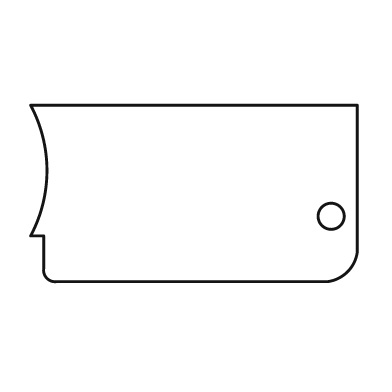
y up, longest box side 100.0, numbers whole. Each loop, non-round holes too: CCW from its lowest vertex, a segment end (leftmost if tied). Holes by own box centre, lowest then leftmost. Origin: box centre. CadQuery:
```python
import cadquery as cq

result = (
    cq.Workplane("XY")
    .moveTo(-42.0, -27.0)
    .lineTo(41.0, -27.0)
    .threePointArc((47.0, -24.0), (50.0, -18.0))
    .lineTo(50.0, 27.0)
    .lineTo(-50.0, 27.0)
    .threePointArc((-45.0, 7.0), (-50.0, -13.0))
    .lineTo(-46.0, -13.0)
    .lineTo(-46.0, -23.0)
    .threePointArc((-45.0, -26.0), (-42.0, -27.0))
    .close()
    .moveTo(42.0, -7.0)
    .circle(4.0)
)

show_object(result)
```